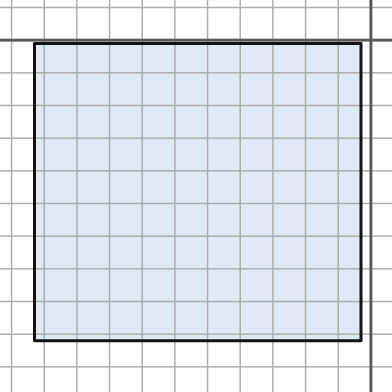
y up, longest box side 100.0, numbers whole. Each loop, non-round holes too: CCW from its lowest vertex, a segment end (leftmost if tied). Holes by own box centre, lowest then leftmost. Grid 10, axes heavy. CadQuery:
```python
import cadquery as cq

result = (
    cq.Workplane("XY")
    .moveTo(-103.0, -92.0)
    .lineTo(-3.0, -92.0)
    .lineTo(-3.0, -1.0)
    .lineTo(-103.0, -1.0)
    .close()
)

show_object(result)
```